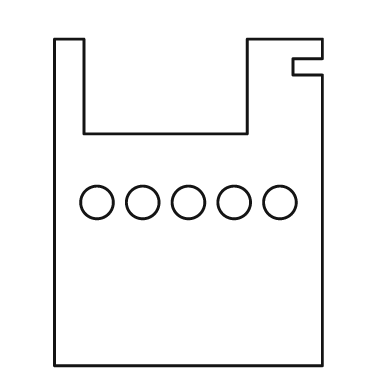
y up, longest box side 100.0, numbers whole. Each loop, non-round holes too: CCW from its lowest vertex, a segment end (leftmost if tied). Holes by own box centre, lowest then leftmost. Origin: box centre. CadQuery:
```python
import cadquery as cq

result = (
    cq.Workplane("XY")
    .moveTo(-41.0, -50.0)
    .lineTo(41.0, -50.0)
    .lineTo(41.0, 39.0)
    .lineTo(32.0, 39.0)
    .lineTo(32.0, 44.0)
    .lineTo(41.0, 44.0)
    .lineTo(41.0, 50.0)
    .lineTo(18.0, 50.0)
    .lineTo(18.0, 21.0)
    .lineTo(-32.0, 21.0)
    .lineTo(-32.0, 50.0)
    .lineTo(-41.0, 50.0)
    .close()
    .moveTo(-28.0, 0.0)
    .circle(5.0)
    .moveTo(-14.0, 0.0)
    .circle(5.0)
    .moveTo(0.0, 0.0)
    .circle(5.0)
    .moveTo(14.0, 0.0)
    .circle(5.0)
    .moveTo(28.0, 0.0)
    .circle(5.0)
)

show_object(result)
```